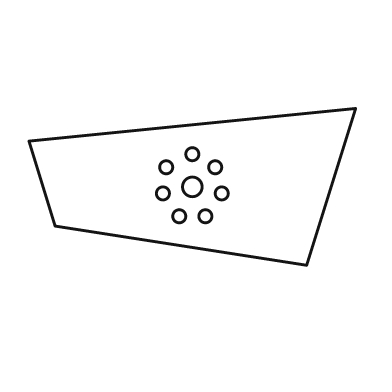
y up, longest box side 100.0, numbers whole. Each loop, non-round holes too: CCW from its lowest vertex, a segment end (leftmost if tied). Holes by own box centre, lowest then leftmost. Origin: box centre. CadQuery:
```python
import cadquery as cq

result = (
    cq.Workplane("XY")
    .moveTo(35.0, -24.0)
    .lineTo(50.0, 24.0)
    .lineTo(-50.0, 14.0)
    .lineTo(-42.0, -12.0)
    .close()
    .moveTo(-4.0, -9.0)
    .circle(2.0)
    .moveTo(4.0, -9.0)
    .circle(2.0)
    .moveTo(-9.0, -2.0)
    .circle(2.0)
    .moveTo(9.0, -2.0)
    .circle(2.0)
    .moveTo(0.0, 0.0)
    .circle(3.0)
    .moveTo(-8.0, 6.0)
    .circle(2.0)
    .moveTo(7.0, 6.0)
    .circle(2.0)
    .moveTo(0.0, 10.0)
    .circle(2.0)
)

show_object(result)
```